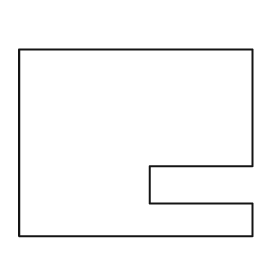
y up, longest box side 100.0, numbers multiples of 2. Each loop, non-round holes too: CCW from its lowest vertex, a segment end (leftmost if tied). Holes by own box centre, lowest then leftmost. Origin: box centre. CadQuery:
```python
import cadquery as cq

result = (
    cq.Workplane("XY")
    .moveTo(-50.0, -40.0)
    .lineTo(50.0, -40.0)
    .lineTo(50.0, -26.0)
    .lineTo(6.0, -26.0)
    .lineTo(6.0, -10.0)
    .lineTo(50.0, -10.0)
    .lineTo(50.0, 40.0)
    .lineTo(-50.0, 40.0)
    .close()
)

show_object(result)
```